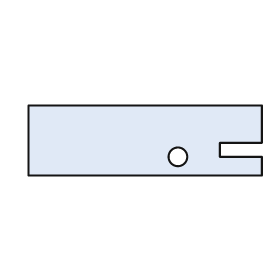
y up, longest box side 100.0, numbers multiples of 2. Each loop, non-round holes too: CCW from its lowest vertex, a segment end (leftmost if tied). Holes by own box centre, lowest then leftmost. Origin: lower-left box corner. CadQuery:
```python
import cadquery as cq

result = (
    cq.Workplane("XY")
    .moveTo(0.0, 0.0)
    .lineTo(100.0, 0.0)
    .lineTo(100.0, 8.0)
    .lineTo(82.0, 8.0)
    .lineTo(82.0, 14.0)
    .lineTo(100.0, 14.0)
    .lineTo(100.0, 30.0)
    .lineTo(0.0, 30.0)
    .close()
    .moveTo(64.0, 8.0)
    .circle(4.0)
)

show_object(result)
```